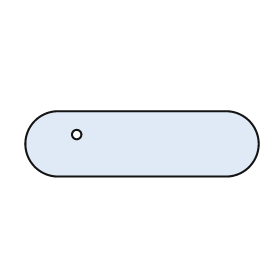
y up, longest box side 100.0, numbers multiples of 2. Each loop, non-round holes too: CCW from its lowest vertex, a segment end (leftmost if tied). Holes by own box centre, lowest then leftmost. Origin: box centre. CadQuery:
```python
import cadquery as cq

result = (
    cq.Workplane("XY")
    .moveTo(-36.0, -14.0)
    .lineTo(36.0, -14.0)
    .threePointArc((50.0, 0.0), (36.0, 14.0))
    .lineTo(-36.0, 14.0)
    .threePointArc((-50.0, 0.0), (-36.0, -14.0))
    .close()
    .moveTo(-28.0, 4.0)
    .circle(2.0)
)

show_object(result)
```